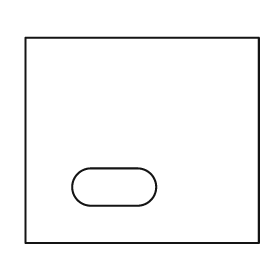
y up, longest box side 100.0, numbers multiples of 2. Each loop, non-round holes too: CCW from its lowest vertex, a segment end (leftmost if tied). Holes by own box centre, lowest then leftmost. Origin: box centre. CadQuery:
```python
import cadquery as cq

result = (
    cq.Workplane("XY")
    .moveTo(-50.0, -44.0)
    .lineTo(50.0, -44.0)
    .lineTo(50.0, 44.0)
    .lineTo(-50.0, 44.0)
    .close()
    .moveTo(-22.0, -28.0)
    .lineTo(-2.0, -28.0)
    .threePointArc((6.0, -20.0), (-2.0, -12.0))
    .lineTo(-22.0, -12.0)
    .threePointArc((-30.0, -20.0), (-22.0, -28.0))
    .close()
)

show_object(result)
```